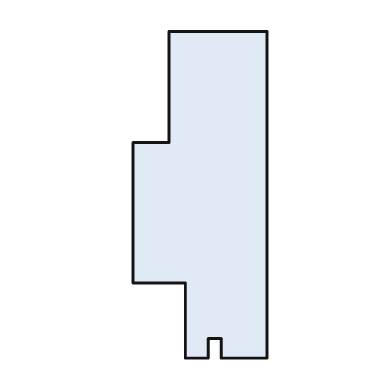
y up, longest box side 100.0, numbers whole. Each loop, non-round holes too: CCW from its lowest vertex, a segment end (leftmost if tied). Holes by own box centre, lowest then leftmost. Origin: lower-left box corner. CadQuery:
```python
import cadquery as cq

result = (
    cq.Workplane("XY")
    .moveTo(16.0, 0.0)
    .lineTo(23.0, 0.0)
    .lineTo(23.0, 6.0)
    .lineTo(27.0, 6.0)
    .lineTo(27.0, 0.0)
    .lineTo(41.0, 0.0)
    .lineTo(41.0, 100.0)
    .lineTo(11.0, 100.0)
    .lineTo(11.0, 66.0)
    .lineTo(0.0, 66.0)
    .lineTo(0.0, 23.0)
    .lineTo(16.0, 23.0)
    .close()
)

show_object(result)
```